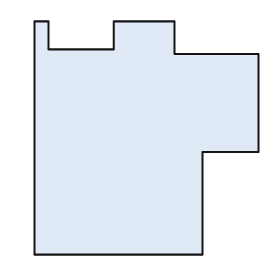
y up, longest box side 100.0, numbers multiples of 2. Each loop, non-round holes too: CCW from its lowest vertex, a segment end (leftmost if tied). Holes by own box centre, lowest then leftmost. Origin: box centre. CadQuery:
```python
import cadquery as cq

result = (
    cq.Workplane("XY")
    .moveTo(-48.0, -50.0)
    .lineTo(24.0, -50.0)
    .lineTo(24.0, -6.0)
    .lineTo(48.0, -6.0)
    .lineTo(48.0, 36.0)
    .lineTo(12.0, 36.0)
    .lineTo(12.0, 50.0)
    .lineTo(-14.0, 50.0)
    .lineTo(-14.0, 38.0)
    .lineTo(-42.0, 38.0)
    .lineTo(-42.0, 50.0)
    .lineTo(-48.0, 50.0)
    .close()
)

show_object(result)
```